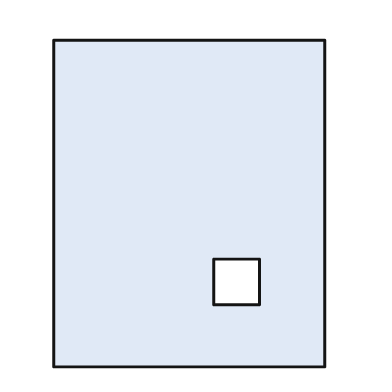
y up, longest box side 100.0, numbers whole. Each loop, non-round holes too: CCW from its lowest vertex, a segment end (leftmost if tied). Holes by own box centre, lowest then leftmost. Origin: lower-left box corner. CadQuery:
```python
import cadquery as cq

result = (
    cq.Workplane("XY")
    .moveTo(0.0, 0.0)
    .lineTo(83.0, 0.0)
    .lineTo(83.0, 100.0)
    .lineTo(0.0, 100.0)
    .close()
    .moveTo(49.0, 19.0)
    .lineTo(63.0, 19.0)
    .lineTo(63.0, 33.0)
    .lineTo(49.0, 33.0)
    .close()
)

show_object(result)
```